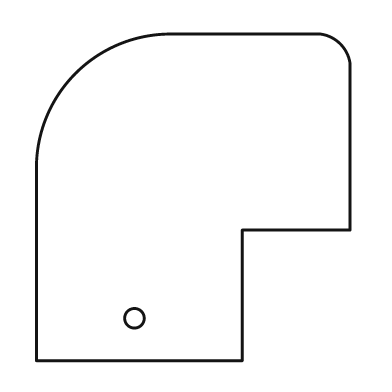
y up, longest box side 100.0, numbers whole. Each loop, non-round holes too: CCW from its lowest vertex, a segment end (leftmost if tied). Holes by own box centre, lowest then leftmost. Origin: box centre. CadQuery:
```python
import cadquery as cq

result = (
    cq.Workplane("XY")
    .moveTo(-48.0, -50.0)
    .lineTo(15.0, -50.0)
    .lineTo(15.0, -10.0)
    .lineTo(48.0, -10.0)
    .lineTo(48.0, 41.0)
    .threePointArc((45.0, 47.0), (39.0, 50.0))
    .lineTo(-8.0, 50.0)
    .threePointArc((-36.0, 38.0), (-48.0, 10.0))
    .close()
    .moveTo(-18.0, -37.0)
    .circle(3.0)
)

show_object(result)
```